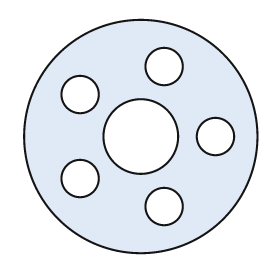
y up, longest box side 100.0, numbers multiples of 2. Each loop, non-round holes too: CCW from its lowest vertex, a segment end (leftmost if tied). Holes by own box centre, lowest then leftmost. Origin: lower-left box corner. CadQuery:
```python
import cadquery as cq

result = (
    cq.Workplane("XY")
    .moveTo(50.0, 50.0)
    .circle(50.0)
    .moveTo(60.0, 20.0)
    .circle(8.0)
    .moveTo(24.0, 32.0)
    .circle(8.0)
    .moveTo(50.0, 50.0)
    .circle(16.0)
    .moveTo(82.0, 50.0)
    .circle(8.0)
    .moveTo(24.0, 68.0)
    .circle(8.0)
    .moveTo(60.0, 80.0)
    .circle(8.0)
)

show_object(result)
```